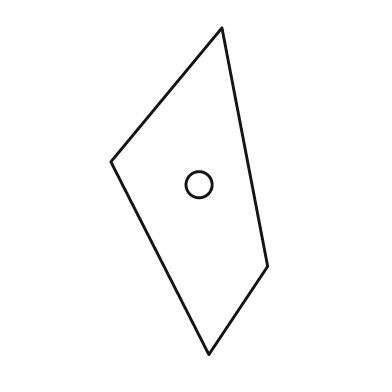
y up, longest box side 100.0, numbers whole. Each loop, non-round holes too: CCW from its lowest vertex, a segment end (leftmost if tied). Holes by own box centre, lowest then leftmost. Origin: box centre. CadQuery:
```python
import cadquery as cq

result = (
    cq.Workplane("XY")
    .moveTo(6.0, -50.0)
    .lineTo(24.0, -23.0)
    .lineTo(10.0, 50.0)
    .lineTo(-24.0, 9.0)
    .close()
    .moveTo(3.0, 2.0)
    .circle(4.0)
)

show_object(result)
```